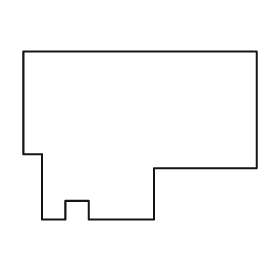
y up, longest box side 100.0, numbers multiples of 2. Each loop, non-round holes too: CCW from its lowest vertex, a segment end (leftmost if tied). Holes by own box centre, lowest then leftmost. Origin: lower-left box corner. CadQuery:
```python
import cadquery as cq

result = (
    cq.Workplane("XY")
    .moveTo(8.0, 0.0)
    .lineTo(18.0, 0.0)
    .lineTo(18.0, 8.0)
    .lineTo(28.0, 8.0)
    .lineTo(28.0, 0.0)
    .lineTo(56.0, 0.0)
    .lineTo(56.0, 22.0)
    .lineTo(100.0, 22.0)
    .lineTo(100.0, 72.0)
    .lineTo(0.0, 72.0)
    .lineTo(0.0, 28.0)
    .lineTo(8.0, 28.0)
    .close()
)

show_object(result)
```